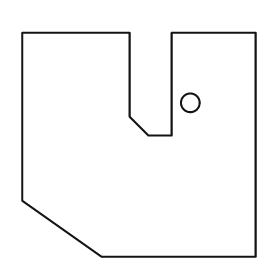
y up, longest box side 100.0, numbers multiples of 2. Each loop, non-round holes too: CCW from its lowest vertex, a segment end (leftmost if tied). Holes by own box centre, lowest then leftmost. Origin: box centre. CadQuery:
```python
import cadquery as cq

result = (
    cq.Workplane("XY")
    .moveTo(-16.0, -48.0)
    .lineTo(50.0, -48.0)
    .lineTo(50.0, 48.0)
    .lineTo(14.0, 48.0)
    .lineTo(14.0, 4.0)
    .lineTo(4.0, 4.0)
    .lineTo(-4.0, 12.0)
    .lineTo(-4.0, 48.0)
    .lineTo(-50.0, 48.0)
    .lineTo(-50.0, -24.0)
    .close()
    .moveTo(22.0, 18.0)
    .circle(4.0)
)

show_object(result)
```